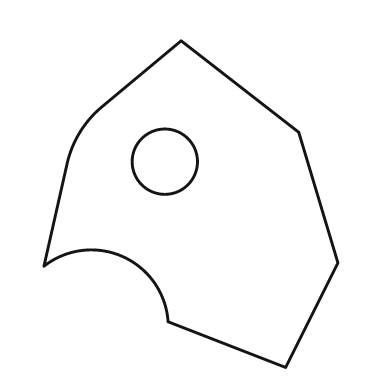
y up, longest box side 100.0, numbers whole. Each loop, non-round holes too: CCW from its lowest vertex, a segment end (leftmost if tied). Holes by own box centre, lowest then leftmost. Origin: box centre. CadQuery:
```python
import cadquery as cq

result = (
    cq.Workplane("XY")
    .moveTo(29.0, -50.0)
    .lineTo(45.0, -18.0)
    .lineTo(33.0, 22.0)
    .lineTo(-3.0, 50.0)
    .lineTo(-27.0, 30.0)
    .threePointArc((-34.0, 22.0), (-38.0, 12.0))
    .lineTo(-45.0, -19.0)
    .threePointArc((-21.0, -16.0), (-7.0, -36.0))
    .close()
    .moveTo(-8.0, 13.0)
    .circle(10.0)
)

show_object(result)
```